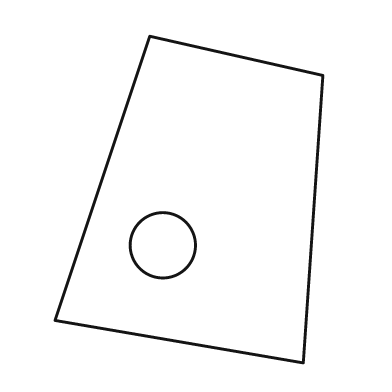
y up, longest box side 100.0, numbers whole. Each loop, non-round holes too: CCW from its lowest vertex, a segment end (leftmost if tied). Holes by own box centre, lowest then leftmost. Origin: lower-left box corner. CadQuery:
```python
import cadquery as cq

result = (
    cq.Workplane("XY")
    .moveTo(76.0, 0.0)
    .lineTo(82.0, 88.0)
    .lineTo(29.0, 100.0)
    .lineTo(0.0, 13.0)
    .close()
    .moveTo(33.0, 36.0)
    .circle(10.0)
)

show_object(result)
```